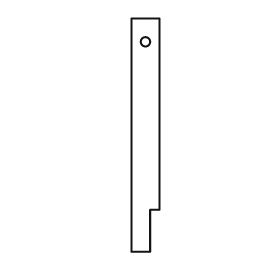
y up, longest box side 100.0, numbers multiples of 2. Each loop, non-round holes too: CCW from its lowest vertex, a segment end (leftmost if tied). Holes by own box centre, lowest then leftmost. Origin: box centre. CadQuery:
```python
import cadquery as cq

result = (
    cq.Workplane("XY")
    .moveTo(-6.0, -50.0)
    .lineTo(2.0, -50.0)
    .lineTo(2.0, -32.0)
    .lineTo(6.0, -32.0)
    .lineTo(6.0, 50.0)
    .lineTo(-6.0, 50.0)
    .close()
    .moveTo(0.0, 40.0)
    .circle(2.0)
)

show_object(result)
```